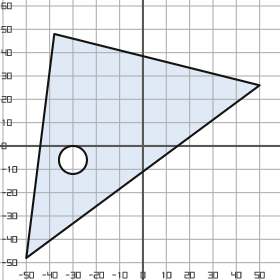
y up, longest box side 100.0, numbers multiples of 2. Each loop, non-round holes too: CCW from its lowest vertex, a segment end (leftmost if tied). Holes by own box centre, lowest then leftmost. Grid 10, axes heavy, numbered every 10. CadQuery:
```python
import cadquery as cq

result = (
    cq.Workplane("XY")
    .moveTo(-50.0, -48.0)
    .lineTo(50.0, 26.0)
    .lineTo(-38.0, 48.0)
    .close()
    .moveTo(-30.0, -6.0)
    .circle(6.0)
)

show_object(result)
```